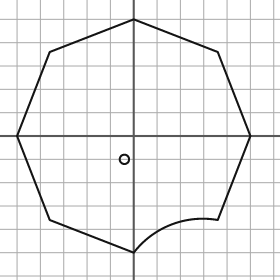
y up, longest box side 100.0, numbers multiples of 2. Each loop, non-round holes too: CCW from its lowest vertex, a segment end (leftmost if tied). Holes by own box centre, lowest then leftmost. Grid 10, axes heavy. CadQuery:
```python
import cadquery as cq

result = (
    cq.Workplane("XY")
    .moveTo(0.0, -50.0)
    .threePointArc((16.0, -38.0), (36.0, -36.0))
    .lineTo(50.0, 0.0)
    .lineTo(36.0, 36.0)
    .lineTo(0.0, 50.0)
    .lineTo(-36.0, 36.0)
    .lineTo(-50.0, 0.0)
    .lineTo(-36.0, -36.0)
    .close()
    .moveTo(-4.0, -10.0)
    .circle(2.0)
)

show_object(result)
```